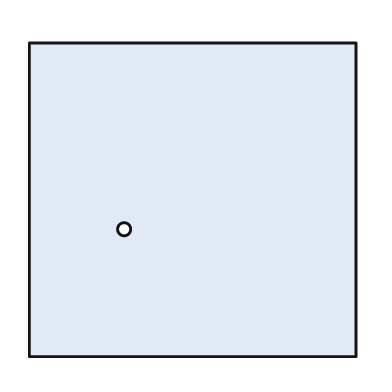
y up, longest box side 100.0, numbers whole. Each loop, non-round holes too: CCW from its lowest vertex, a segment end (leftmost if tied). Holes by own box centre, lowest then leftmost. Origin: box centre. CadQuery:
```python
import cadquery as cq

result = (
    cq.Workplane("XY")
    .moveTo(-50.0, -48.0)
    .lineTo(50.0, -48.0)
    .lineTo(50.0, 48.0)
    .lineTo(-50.0, 48.0)
    .close()
    .moveTo(-21.0, -9.0)
    .circle(2.0)
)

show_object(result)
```